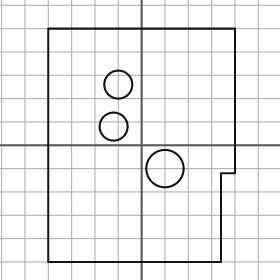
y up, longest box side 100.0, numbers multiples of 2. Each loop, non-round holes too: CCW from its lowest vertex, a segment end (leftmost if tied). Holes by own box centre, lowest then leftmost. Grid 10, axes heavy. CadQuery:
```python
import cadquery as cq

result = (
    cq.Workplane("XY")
    .moveTo(-40.0, -50.0)
    .lineTo(34.0, -50.0)
    .lineTo(34.0, -12.0)
    .lineTo(40.0, -12.0)
    .lineTo(40.0, 50.0)
    .lineTo(-40.0, 50.0)
    .close()
    .moveTo(10.0, -10.0)
    .circle(8.0)
    .moveTo(-12.0, 8.0)
    .circle(6.0)
    .moveTo(-10.0, 26.0)
    .circle(6.0)
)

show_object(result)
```